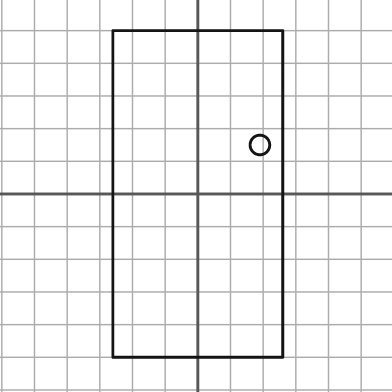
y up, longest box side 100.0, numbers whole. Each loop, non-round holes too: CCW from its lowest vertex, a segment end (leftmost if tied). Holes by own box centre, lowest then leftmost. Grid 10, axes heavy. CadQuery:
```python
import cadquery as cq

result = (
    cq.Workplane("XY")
    .moveTo(-26.0, -50.0)
    .lineTo(26.0, -50.0)
    .lineTo(26.0, 50.0)
    .lineTo(-26.0, 50.0)
    .close()
    .moveTo(19.0, 15.0)
    .circle(3.0)
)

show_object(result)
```